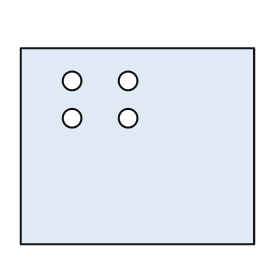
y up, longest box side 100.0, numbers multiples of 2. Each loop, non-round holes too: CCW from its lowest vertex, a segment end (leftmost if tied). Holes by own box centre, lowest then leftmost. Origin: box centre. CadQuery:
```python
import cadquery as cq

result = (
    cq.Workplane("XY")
    .moveTo(-50.0, -42.0)
    .lineTo(50.0, -42.0)
    .lineTo(50.0, 42.0)
    .lineTo(-50.0, 42.0)
    .close()
    .moveTo(-28.0, 12.0)
    .circle(4.0)
    .moveTo(-4.0, 12.0)
    .circle(4.0)
    .moveTo(-28.0, 28.0)
    .circle(4.0)
    .moveTo(-4.0, 28.0)
    .circle(4.0)
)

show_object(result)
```